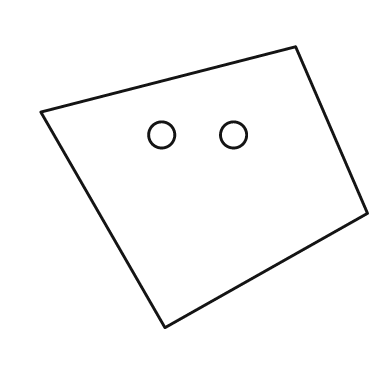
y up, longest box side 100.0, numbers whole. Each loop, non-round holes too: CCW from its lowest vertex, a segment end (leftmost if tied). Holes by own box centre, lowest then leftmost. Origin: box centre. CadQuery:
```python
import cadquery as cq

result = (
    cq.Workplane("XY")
    .moveTo(-12.0, -43.0)
    .lineTo(50.0, -8.0)
    .lineTo(28.0, 43.0)
    .lineTo(-50.0, 23.0)
    .close()
    .moveTo(-13.0, 16.0)
    .circle(4.0)
    .moveTo(9.0, 16.0)
    .circle(4.0)
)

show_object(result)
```